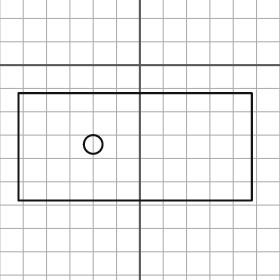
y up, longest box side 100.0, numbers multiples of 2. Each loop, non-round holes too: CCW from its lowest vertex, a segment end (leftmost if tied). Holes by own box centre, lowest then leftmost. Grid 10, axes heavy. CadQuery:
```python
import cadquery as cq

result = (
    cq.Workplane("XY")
    .moveTo(-52.0, -58.0)
    .lineTo(48.0, -58.0)
    .lineTo(48.0, -12.0)
    .lineTo(-52.0, -12.0)
    .close()
    .moveTo(-20.0, -34.0)
    .circle(4.0)
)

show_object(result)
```